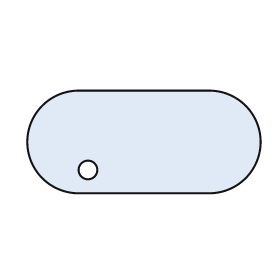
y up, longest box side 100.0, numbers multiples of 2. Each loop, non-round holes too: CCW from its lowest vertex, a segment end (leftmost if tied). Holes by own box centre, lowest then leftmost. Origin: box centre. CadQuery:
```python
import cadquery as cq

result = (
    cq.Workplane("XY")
    .moveTo(-28.0, -22.0)
    .lineTo(28.0, -22.0)
    .threePointArc((50.0, 0.0), (28.0, 22.0))
    .lineTo(-28.0, 22.0)
    .threePointArc((-50.0, 0.0), (-28.0, -22.0))
    .close()
    .moveTo(-24.0, -12.0)
    .circle(4.0)
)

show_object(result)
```